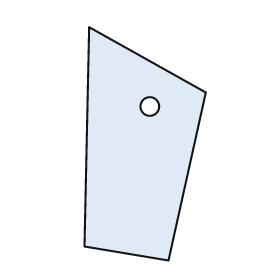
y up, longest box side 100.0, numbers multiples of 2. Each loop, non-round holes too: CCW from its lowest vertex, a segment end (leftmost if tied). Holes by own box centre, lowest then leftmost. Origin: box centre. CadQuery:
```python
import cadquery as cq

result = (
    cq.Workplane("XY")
    .moveTo(10.0, -50.0)
    .lineTo(26.0, 22.0)
    .lineTo(-24.0, 50.0)
    .lineTo(-26.0, -44.0)
    .close()
    .moveTo(2.0, 16.0)
    .circle(4.0)
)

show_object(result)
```